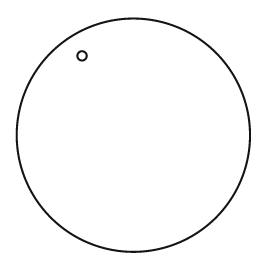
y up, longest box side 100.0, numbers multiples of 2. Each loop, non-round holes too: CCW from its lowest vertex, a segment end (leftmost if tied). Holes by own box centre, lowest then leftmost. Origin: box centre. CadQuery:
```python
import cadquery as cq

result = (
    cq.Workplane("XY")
    .moveTo(0.0, 0.0)
    .circle(50.0)
    .moveTo(-22.0, 34.0)
    .circle(2.0)
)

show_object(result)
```